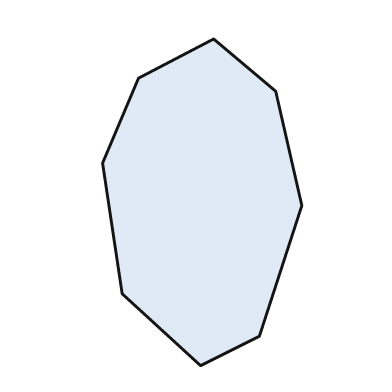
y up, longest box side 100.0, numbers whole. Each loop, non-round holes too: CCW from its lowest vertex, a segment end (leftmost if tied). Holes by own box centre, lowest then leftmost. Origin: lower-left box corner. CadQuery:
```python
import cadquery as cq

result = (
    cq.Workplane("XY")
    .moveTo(30.0, 0.0)
    .lineTo(48.0, 9.0)
    .lineTo(61.0, 49.0)
    .lineTo(53.0, 84.0)
    .lineTo(34.0, 100.0)
    .lineTo(11.0, 88.0)
    .lineTo(0.0, 62.0)
    .lineTo(6.0, 22.0)
    .close()
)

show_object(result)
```